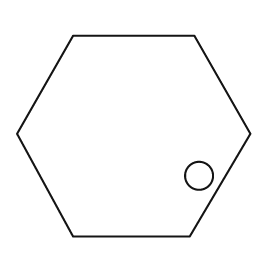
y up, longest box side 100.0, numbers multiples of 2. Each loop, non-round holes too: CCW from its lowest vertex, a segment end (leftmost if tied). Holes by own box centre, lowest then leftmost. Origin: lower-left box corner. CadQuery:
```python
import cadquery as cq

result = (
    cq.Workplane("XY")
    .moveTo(24.0, 0.0)
    .lineTo(74.0, 0.0)
    .lineTo(100.0, 44.0)
    .lineTo(76.0, 86.0)
    .lineTo(24.0, 86.0)
    .lineTo(0.0, 44.0)
    .close()
    .moveTo(78.0, 26.0)
    .circle(6.0)
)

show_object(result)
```